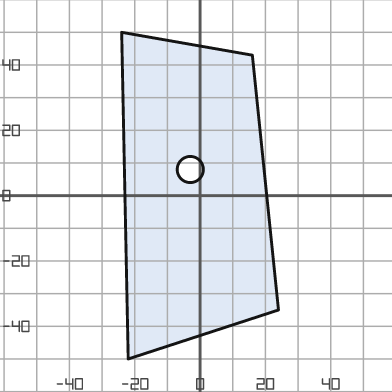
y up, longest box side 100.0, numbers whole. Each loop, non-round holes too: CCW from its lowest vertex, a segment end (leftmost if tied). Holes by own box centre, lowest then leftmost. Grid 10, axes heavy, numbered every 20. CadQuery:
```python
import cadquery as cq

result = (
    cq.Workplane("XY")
    .moveTo(-22.0, -50.0)
    .lineTo(24.0, -35.0)
    .lineTo(16.0, 43.0)
    .lineTo(-24.0, 50.0)
    .close()
    .moveTo(-3.0, 8.0)
    .circle(4.0)
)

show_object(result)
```